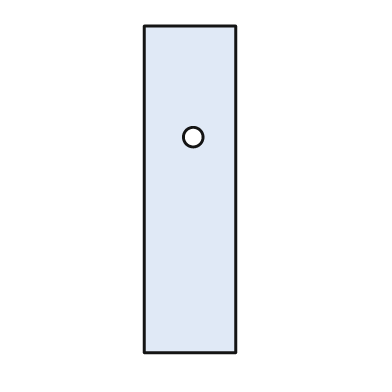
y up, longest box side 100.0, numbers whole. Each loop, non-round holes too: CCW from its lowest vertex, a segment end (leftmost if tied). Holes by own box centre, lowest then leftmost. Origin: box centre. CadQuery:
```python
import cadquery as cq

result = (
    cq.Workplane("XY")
    .moveTo(-14.0, -50.0)
    .lineTo(14.0, -50.0)
    .lineTo(14.0, 50.0)
    .lineTo(-14.0, 50.0)
    .close()
    .moveTo(1.0, 16.0)
    .circle(3.0)
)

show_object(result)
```